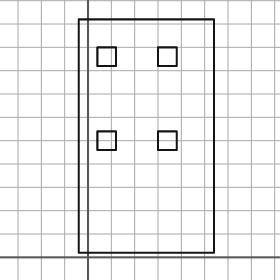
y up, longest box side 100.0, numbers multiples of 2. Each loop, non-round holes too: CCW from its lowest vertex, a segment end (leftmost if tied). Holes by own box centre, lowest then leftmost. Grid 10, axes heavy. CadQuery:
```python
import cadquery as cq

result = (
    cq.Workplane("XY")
    .moveTo(-4.0, 2.0)
    .lineTo(54.0, 2.0)
    .lineTo(54.0, 102.0)
    .lineTo(-4.0, 102.0)
    .close()
    .moveTo(4.0, 46.0)
    .lineTo(12.0, 46.0)
    .lineTo(12.0, 54.0)
    .lineTo(4.0, 54.0)
    .close()
    .moveTo(30.0, 46.0)
    .lineTo(38.0, 46.0)
    .lineTo(38.0, 54.0)
    .lineTo(30.0, 54.0)
    .close()
    .moveTo(4.0, 82.0)
    .lineTo(12.0, 82.0)
    .lineTo(12.0, 90.0)
    .lineTo(4.0, 90.0)
    .close()
    .moveTo(30.0, 82.0)
    .lineTo(38.0, 82.0)
    .lineTo(38.0, 90.0)
    .lineTo(30.0, 90.0)
    .close()
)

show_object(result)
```